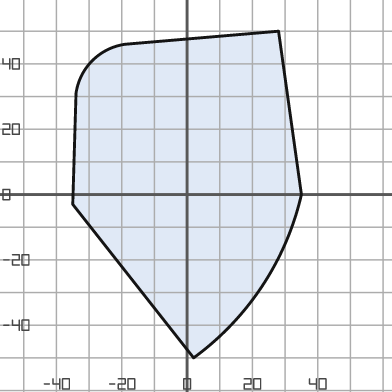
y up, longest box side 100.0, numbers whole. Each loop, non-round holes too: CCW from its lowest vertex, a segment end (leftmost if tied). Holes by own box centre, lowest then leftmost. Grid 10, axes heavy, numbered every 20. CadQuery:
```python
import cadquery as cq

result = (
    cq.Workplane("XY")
    .moveTo(2.0, -50.0)
    .threePointArc((23.0, -28.0), (35.0, 0.0))
    .lineTo(28.0, 50.0)
    .lineTo(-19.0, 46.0)
    .threePointArc((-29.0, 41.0), (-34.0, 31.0))
    .lineTo(-35.0, -3.0)
    .close()
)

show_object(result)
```